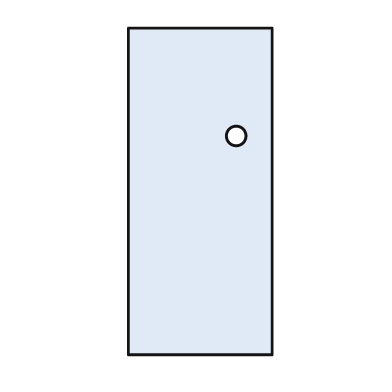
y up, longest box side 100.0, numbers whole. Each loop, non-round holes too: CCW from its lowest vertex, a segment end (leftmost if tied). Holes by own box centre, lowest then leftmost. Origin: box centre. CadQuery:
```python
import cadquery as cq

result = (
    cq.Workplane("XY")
    .moveTo(-22.0, -50.0)
    .lineTo(22.0, -50.0)
    .lineTo(22.0, 50.0)
    .lineTo(-22.0, 50.0)
    .close()
    .moveTo(11.0, 17.0)
    .circle(3.0)
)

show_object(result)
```